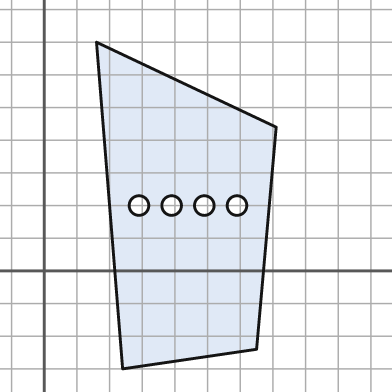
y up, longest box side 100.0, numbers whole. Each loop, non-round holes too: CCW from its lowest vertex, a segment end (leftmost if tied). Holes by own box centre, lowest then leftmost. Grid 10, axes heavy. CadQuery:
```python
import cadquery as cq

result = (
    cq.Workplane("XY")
    .moveTo(24.0, -30.0)
    .lineTo(65.0, -24.0)
    .lineTo(71.0, 44.0)
    .lineTo(16.0, 70.0)
    .close()
    .moveTo(29.0, 20.0)
    .circle(3.0)
    .moveTo(39.0, 20.0)
    .circle(3.0)
    .moveTo(49.0, 20.0)
    .circle(3.0)
    .moveTo(59.0, 20.0)
    .circle(3.0)
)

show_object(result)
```